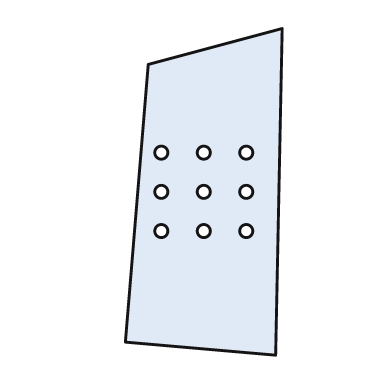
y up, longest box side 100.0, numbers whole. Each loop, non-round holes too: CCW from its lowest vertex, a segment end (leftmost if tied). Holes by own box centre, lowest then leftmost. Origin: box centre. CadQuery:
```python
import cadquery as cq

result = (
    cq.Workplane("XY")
    .moveTo(22.0, -50.0)
    .lineTo(24.0, 50.0)
    .lineTo(-17.0, 39.0)
    .lineTo(-24.0, -46.0)
    .close()
    .moveTo(-13.0, -12.0)
    .circle(2.0)
    .moveTo(0.0, -12.0)
    .circle(2.0)
    .moveTo(13.0, -12.0)
    .circle(2.0)
    .moveTo(-13.0, 0.0)
    .circle(2.0)
    .moveTo(0.0, 0.0)
    .circle(2.0)
    .moveTo(13.0, 0.0)
    .circle(2.0)
    .moveTo(-13.0, 12.0)
    .circle(2.0)
    .moveTo(0.0, 12.0)
    .circle(2.0)
    .moveTo(13.0, 12.0)
    .circle(2.0)
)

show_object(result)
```